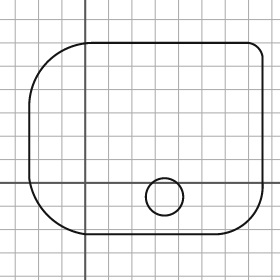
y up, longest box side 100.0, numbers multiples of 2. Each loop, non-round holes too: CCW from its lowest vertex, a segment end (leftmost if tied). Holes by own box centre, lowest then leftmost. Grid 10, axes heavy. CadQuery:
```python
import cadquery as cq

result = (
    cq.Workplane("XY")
    .moveTo(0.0, -22.0)
    .lineTo(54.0, -22.0)
    .threePointArc((70.0, -16.0), (76.0, 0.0))
    .lineTo(76.0, 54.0)
    .threePointArc((74.0, 58.0), (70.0, 60.0))
    .lineTo(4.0, 60.0)
    .threePointArc((-16.0, 52.0), (-24.0, 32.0))
    .lineTo(-24.0, 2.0)
    .threePointArc((-16.0, -14.0), (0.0, -22.0))
    .close()
    .moveTo(34.0, -6.0)
    .circle(8.0)
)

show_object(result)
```